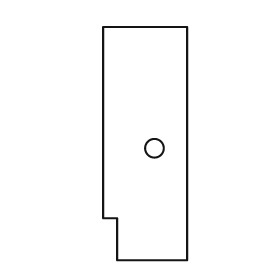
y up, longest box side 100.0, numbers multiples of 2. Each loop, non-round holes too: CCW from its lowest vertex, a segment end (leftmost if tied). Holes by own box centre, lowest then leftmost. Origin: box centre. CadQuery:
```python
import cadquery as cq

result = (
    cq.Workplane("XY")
    .moveTo(-12.0, -50.0)
    .lineTo(18.0, -50.0)
    .lineTo(18.0, 50.0)
    .lineTo(-18.0, 50.0)
    .lineTo(-18.0, -32.0)
    .lineTo(-12.0, -32.0)
    .close()
    .moveTo(4.0, -2.0)
    .circle(4.0)
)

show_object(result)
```